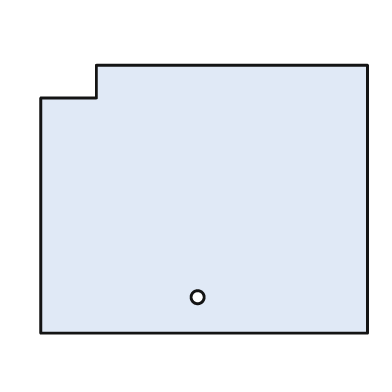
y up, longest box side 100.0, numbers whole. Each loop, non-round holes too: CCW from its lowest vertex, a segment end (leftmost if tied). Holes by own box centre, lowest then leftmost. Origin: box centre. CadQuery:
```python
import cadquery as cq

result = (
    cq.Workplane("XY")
    .moveTo(-50.0, -41.0)
    .lineTo(50.0, -41.0)
    .lineTo(50.0, 41.0)
    .lineTo(-33.0, 41.0)
    .lineTo(-33.0, 31.0)
    .lineTo(-50.0, 31.0)
    .close()
    .moveTo(-2.0, -30.0)
    .circle(2.0)
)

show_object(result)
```